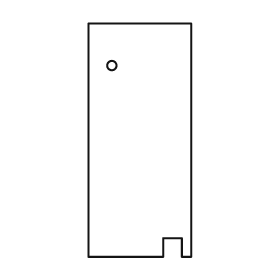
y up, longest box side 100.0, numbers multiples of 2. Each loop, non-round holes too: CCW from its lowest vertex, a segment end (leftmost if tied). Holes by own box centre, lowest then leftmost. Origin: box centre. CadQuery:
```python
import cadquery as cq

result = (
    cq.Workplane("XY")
    .moveTo(-22.0, -50.0)
    .lineTo(10.0, -50.0)
    .lineTo(10.0, -42.0)
    .lineTo(18.0, -42.0)
    .lineTo(18.0, -50.0)
    .lineTo(22.0, -50.0)
    .lineTo(22.0, 50.0)
    .lineTo(-22.0, 50.0)
    .close()
    .moveTo(-12.0, 32.0)
    .circle(2.0)
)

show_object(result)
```